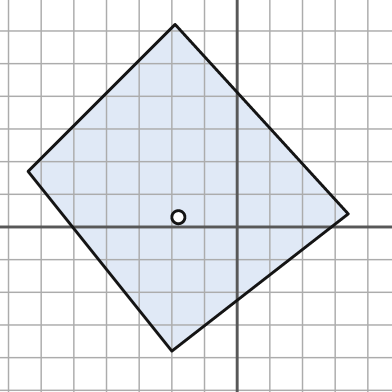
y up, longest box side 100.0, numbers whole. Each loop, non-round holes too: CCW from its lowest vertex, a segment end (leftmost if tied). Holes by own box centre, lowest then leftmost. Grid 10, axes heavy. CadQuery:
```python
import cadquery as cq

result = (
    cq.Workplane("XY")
    .moveTo(-20.0, -38.0)
    .lineTo(34.0, 4.0)
    .lineTo(-19.0, 62.0)
    .lineTo(-64.0, 17.0)
    .close()
    .moveTo(-18.0, 3.0)
    .circle(2.0)
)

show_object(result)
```